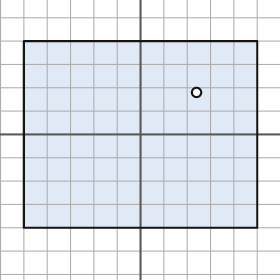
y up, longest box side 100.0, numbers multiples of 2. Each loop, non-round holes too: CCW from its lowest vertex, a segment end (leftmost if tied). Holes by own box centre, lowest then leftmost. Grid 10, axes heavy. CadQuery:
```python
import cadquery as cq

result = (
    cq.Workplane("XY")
    .moveTo(-50.0, -40.0)
    .lineTo(50.0, -40.0)
    .lineTo(50.0, 40.0)
    .lineTo(-50.0, 40.0)
    .close()
    .moveTo(24.0, 18.0)
    .circle(2.0)
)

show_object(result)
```